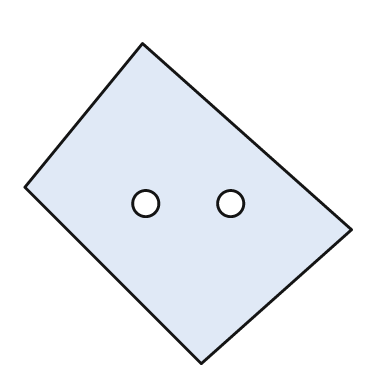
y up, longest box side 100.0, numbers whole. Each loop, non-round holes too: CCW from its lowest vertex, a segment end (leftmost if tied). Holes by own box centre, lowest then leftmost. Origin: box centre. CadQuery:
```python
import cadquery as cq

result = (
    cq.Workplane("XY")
    .moveTo(4.0, -49.0)
    .lineTo(50.0, -8.0)
    .lineTo(-14.0, 49.0)
    .lineTo(-50.0, 5.0)
    .close()
    .moveTo(-13.0, 0.0)
    .circle(4.0)
    .moveTo(13.0, 0.0)
    .circle(4.0)
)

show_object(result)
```